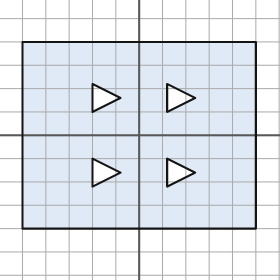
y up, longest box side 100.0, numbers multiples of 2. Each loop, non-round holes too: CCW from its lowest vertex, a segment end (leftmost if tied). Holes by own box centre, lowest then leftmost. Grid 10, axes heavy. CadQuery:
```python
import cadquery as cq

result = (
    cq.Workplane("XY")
    .moveTo(-50.0, -40.0)
    .lineTo(50.0, -40.0)
    .lineTo(50.0, 40.0)
    .lineTo(-50.0, 40.0)
    .close()
    .moveTo(-20.0, -22.0)
    .lineTo(-8.0, -16.0)
    .lineTo(-20.0, -10.0)
    .close()
    .moveTo(12.0, -22.0)
    .lineTo(24.0, -16.0)
    .lineTo(12.0, -10.0)
    .close()
    .moveTo(-20.0, 10.0)
    .lineTo(-8.0, 16.0)
    .lineTo(-20.0, 22.0)
    .close()
    .moveTo(12.0, 10.0)
    .lineTo(24.0, 16.0)
    .lineTo(12.0, 22.0)
    .close()
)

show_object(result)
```